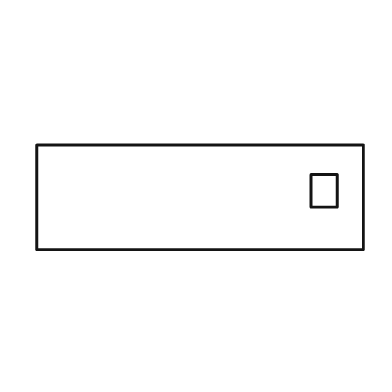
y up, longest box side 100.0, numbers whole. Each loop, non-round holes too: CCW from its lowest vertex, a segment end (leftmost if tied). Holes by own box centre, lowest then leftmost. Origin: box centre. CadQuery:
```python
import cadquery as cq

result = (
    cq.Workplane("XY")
    .moveTo(-50.0, -16.0)
    .lineTo(50.0, -16.0)
    .lineTo(50.0, 16.0)
    .lineTo(-50.0, 16.0)
    .close()
    .moveTo(34.0, -3.0)
    .lineTo(42.0, -3.0)
    .lineTo(42.0, 7.0)
    .lineTo(34.0, 7.0)
    .close()
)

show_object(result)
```